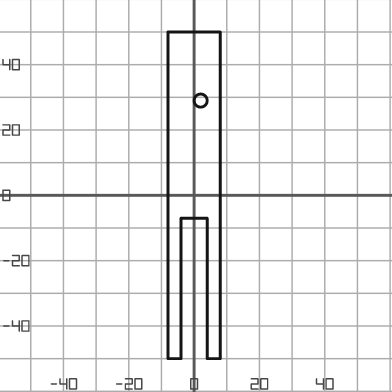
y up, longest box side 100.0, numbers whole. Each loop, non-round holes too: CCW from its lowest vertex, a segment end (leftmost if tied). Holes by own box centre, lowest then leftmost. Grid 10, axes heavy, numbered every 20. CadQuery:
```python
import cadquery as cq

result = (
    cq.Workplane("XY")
    .moveTo(-8.0, -50.0)
    .lineTo(-4.0, -50.0)
    .lineTo(-4.0, -7.0)
    .lineTo(4.0, -7.0)
    .lineTo(4.0, -50.0)
    .lineTo(8.0, -50.0)
    .lineTo(8.0, 50.0)
    .lineTo(-8.0, 50.0)
    .close()
    .moveTo(2.0, 29.0)
    .circle(2.0)
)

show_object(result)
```